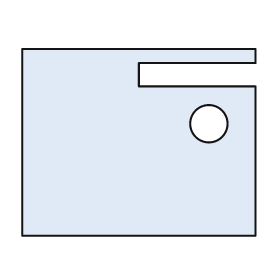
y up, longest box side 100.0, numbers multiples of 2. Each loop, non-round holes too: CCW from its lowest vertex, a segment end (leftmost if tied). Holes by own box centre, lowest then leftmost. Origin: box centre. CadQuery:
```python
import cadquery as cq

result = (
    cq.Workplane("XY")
    .moveTo(-50.0, -40.0)
    .lineTo(50.0, -40.0)
    .lineTo(50.0, 24.0)
    .lineTo(0.0, 24.0)
    .lineTo(0.0, 34.0)
    .lineTo(50.0, 34.0)
    .lineTo(50.0, 40.0)
    .lineTo(-50.0, 40.0)
    .close()
    .moveTo(30.0, 8.0)
    .circle(8.0)
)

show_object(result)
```